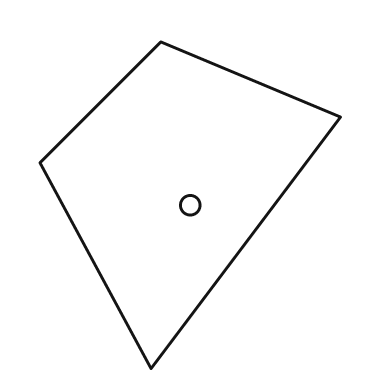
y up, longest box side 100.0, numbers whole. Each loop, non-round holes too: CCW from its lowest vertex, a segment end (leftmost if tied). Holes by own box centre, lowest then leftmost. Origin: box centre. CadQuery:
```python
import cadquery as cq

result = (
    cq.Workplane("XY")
    .moveTo(-12.0, -50.0)
    .lineTo(46.0, 27.0)
    .lineTo(-9.0, 50.0)
    .lineTo(-46.0, 13.0)
    .close()
    .moveTo(0.0, 0.0)
    .circle(3.0)
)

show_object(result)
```